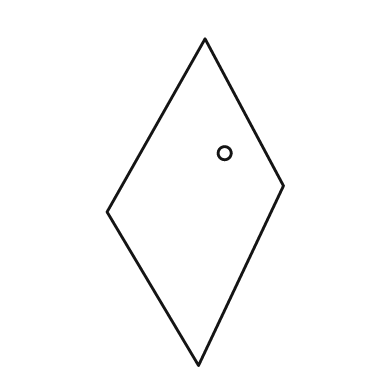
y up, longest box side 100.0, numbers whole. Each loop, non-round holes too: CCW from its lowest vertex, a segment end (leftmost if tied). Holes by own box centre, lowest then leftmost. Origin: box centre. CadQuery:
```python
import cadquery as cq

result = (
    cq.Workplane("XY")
    .moveTo(1.0, -50.0)
    .lineTo(27.0, 5.0)
    .lineTo(3.0, 50.0)
    .lineTo(-27.0, -3.0)
    .close()
    .moveTo(9.0, 15.0)
    .circle(2.0)
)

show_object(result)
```